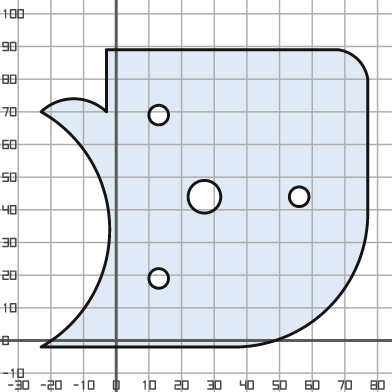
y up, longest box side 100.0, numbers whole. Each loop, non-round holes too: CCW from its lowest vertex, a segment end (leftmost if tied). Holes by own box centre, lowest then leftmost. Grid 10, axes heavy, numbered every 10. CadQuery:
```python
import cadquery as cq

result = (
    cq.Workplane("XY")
    .moveTo(-23.0, -2.0)
    .lineTo(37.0, -2.0)
    .threePointArc((65.0, 10.0), (77.0, 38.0))
    .lineTo(77.0, 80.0)
    .threePointArc((74.0, 86.0), (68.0, 89.0))
    .lineTo(-3.0, 89.0)
    .lineTo(-3.0, 70.0)
    .threePointArc((-13.0, 74.0), (-23.0, 70.0))
    .threePointArc((-2.0, 34.0), (-23.0, -2.0))
    .close()
    .moveTo(13.0, 19.0)
    .circle(3.0)
    .moveTo(27.0, 44.0)
    .circle(5.0)
    .moveTo(56.0, 44.0)
    .circle(3.0)
    .moveTo(13.0, 69.0)
    .circle(3.0)
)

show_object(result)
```